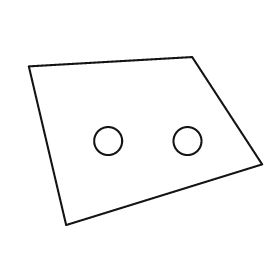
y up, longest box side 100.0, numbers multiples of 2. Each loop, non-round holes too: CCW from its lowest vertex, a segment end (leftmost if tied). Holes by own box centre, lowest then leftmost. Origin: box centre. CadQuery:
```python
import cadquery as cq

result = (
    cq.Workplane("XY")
    .moveTo(-34.0, -36.0)
    .lineTo(50.0, -10.0)
    .lineTo(20.0, 36.0)
    .lineTo(-50.0, 32.0)
    .close()
    .moveTo(-16.0, 0.0)
    .circle(6.0)
    .moveTo(18.0, 0.0)
    .circle(6.0)
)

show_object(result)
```